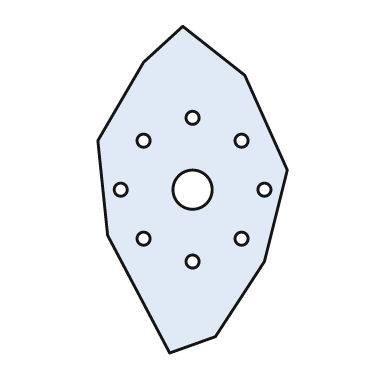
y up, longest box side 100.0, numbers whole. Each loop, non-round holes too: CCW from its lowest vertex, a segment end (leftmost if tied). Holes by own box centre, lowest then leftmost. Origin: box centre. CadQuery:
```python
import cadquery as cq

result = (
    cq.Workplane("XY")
    .moveTo(-7.0, -50.0)
    .lineTo(7.0, -45.0)
    .lineTo(22.0, -22.0)
    .lineTo(29.0, 6.0)
    .lineTo(16.0, 35.0)
    .lineTo(-3.0, 50.0)
    .lineTo(-15.0, 39.0)
    .lineTo(-29.0, 15.0)
    .lineTo(-26.0, -14.0)
    .close()
    .moveTo(0.0, -22.0)
    .circle(2.0)
    .moveTo(-15.0, -15.0)
    .circle(2.0)
    .moveTo(15.0, -15.0)
    .circle(2.0)
    .moveTo(-22.0, 0.0)
    .circle(2.0)
    .moveTo(0.0, 0.0)
    .circle(6.0)
    .moveTo(22.0, 0.0)
    .circle(2.0)
    .moveTo(-15.0, 15.0)
    .circle(2.0)
    .moveTo(15.0, 15.0)
    .circle(2.0)
    .moveTo(0.0, 22.0)
    .circle(2.0)
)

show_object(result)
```